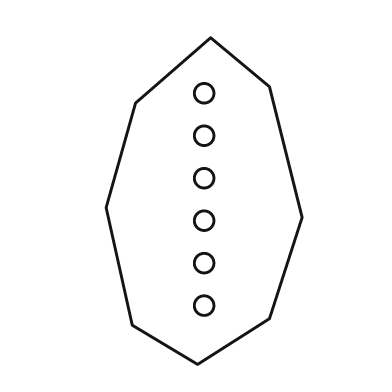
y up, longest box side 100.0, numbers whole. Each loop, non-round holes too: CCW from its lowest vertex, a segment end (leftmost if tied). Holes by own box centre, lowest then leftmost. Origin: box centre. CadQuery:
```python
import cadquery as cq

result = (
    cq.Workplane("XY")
    .moveTo(-2.0, -50.0)
    .lineTo(20.0, -36.0)
    .lineTo(30.0, -5.0)
    .lineTo(20.0, 35.0)
    .lineTo(2.0, 50.0)
    .lineTo(-21.0, 30.0)
    .lineTo(-30.0, -2.0)
    .lineTo(-22.0, -38.0)
    .close()
    .moveTo(0.0, -32.0)
    .circle(3.0)
    .moveTo(0.0, -19.0)
    .circle(3.0)
    .moveTo(0.0, -6.0)
    .circle(3.0)
    .moveTo(0.0, 7.0)
    .circle(3.0)
    .moveTo(0.0, 20.0)
    .circle(3.0)
    .moveTo(0.0, 33.0)
    .circle(3.0)
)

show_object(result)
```